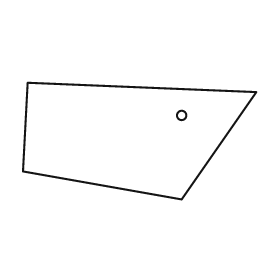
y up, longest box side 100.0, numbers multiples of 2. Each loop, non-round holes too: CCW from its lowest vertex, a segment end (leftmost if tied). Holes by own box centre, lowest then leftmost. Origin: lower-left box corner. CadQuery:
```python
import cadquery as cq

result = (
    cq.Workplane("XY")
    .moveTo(68.0, 0.0)
    .lineTo(100.0, 46.0)
    .lineTo(2.0, 50.0)
    .lineTo(0.0, 12.0)
    .close()
    .moveTo(68.0, 36.0)
    .circle(2.0)
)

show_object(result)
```